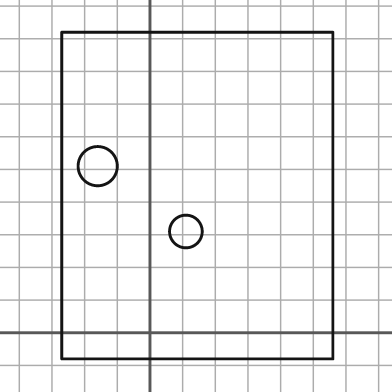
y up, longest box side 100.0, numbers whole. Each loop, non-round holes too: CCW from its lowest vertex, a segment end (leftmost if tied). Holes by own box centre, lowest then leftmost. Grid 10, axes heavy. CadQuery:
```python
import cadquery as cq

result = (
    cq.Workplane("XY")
    .moveTo(-27.0, -8.0)
    .lineTo(56.0, -8.0)
    .lineTo(56.0, 92.0)
    .lineTo(-27.0, 92.0)
    .close()
    .moveTo(11.0, 31.0)
    .circle(5.0)
    .moveTo(-16.0, 51.0)
    .circle(6.0)
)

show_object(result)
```